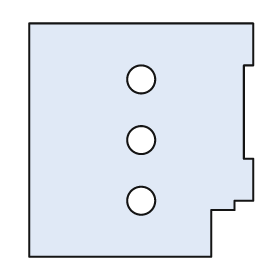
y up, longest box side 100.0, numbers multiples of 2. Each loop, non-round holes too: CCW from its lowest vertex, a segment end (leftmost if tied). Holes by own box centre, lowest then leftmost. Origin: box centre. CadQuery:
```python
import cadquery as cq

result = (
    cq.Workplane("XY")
    .moveTo(-48.0, -50.0)
    .lineTo(30.0, -50.0)
    .lineTo(30.0, -30.0)
    .lineTo(40.0, -30.0)
    .lineTo(40.0, -26.0)
    .lineTo(48.0, -26.0)
    .lineTo(48.0, -8.0)
    .lineTo(44.0, -8.0)
    .lineTo(44.0, 32.0)
    .lineTo(48.0, 32.0)
    .lineTo(48.0, 50.0)
    .lineTo(-48.0, 50.0)
    .close()
    .moveTo(0.0, -26.0)
    .circle(6.0)
    .moveTo(0.0, 0.0)
    .circle(6.0)
    .moveTo(0.0, 26.0)
    .circle(6.0)
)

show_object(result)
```